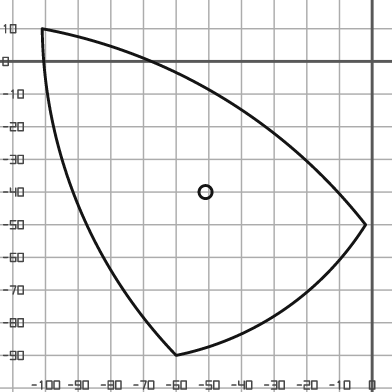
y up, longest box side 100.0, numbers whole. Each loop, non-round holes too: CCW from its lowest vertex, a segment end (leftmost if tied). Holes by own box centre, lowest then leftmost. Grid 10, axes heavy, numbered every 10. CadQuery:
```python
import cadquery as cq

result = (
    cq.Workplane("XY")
    .moveTo(-60.0, -90.0)
    .threePointArc((-27.0, -76.0), (-2.0, -50.0))
    .threePointArc((-46.0, -11.0), (-101.0, 10.0))
    .threePointArc((-90.0, -44.0), (-60.0, -90.0))
    .close()
    .moveTo(-51.0, -40.0)
    .circle(2.0)
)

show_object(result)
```